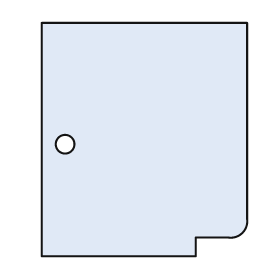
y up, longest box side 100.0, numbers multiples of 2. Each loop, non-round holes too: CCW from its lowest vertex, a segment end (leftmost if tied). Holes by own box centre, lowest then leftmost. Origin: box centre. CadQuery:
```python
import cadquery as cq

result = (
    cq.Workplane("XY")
    .moveTo(-44.0, -50.0)
    .lineTo(22.0, -50.0)
    .lineTo(22.0, -42.0)
    .lineTo(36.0, -42.0)
    .threePointArc((42.0, -40.0), (44.0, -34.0))
    .lineTo(44.0, 50.0)
    .lineTo(-44.0, 50.0)
    .close()
    .moveTo(-34.0, -2.0)
    .circle(4.0)
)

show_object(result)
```